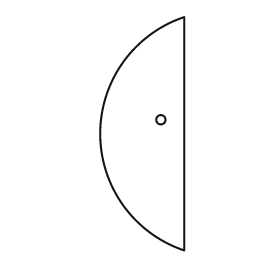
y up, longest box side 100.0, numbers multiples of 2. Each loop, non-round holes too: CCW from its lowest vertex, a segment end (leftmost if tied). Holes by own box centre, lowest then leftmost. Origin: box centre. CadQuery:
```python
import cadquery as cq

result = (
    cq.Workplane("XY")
    .moveTo(18.0, -50.0)
    .lineTo(18.0, 50.0)
    .threePointArc((-18.0, 0.0), (18.0, -50.0))
    .close()
    .moveTo(8.0, 6.0)
    .circle(2.0)
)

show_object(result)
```